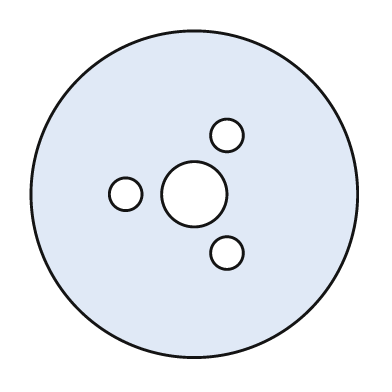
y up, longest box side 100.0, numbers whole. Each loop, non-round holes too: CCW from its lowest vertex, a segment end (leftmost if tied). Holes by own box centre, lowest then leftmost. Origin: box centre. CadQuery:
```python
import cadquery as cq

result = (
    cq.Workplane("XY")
    .moveTo(0.0, 0.0)
    .circle(50.0)
    .moveTo(10.0, -18.0)
    .circle(5.0)
    .moveTo(-21.0, 0.0)
    .circle(5.0)
    .moveTo(0.0, 0.0)
    .circle(10.0)
    .moveTo(10.0, 18.0)
    .circle(5.0)
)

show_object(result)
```